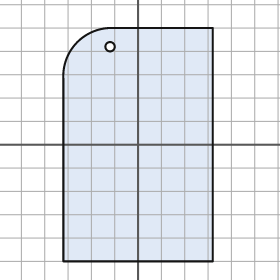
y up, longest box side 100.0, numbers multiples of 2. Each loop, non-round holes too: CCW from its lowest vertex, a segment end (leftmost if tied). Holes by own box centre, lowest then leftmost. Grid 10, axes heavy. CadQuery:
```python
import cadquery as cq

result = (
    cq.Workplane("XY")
    .moveTo(-32.0, -50.0)
    .lineTo(32.0, -50.0)
    .lineTo(32.0, 50.0)
    .lineTo(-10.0, 50.0)
    .threePointArc((-26.0, 44.0), (-32.0, 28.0))
    .close()
    .moveTo(-12.0, 42.0)
    .circle(2.0)
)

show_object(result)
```